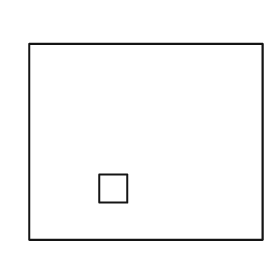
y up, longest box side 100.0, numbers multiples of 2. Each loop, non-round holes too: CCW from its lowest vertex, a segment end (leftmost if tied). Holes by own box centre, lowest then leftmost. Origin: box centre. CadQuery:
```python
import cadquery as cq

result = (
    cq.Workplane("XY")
    .moveTo(-50.0, -42.0)
    .lineTo(50.0, -42.0)
    .lineTo(50.0, 42.0)
    .lineTo(-50.0, 42.0)
    .close()
    .moveTo(-20.0, -26.0)
    .lineTo(-8.0, -26.0)
    .lineTo(-8.0, -14.0)
    .lineTo(-20.0, -14.0)
    .close()
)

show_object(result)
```